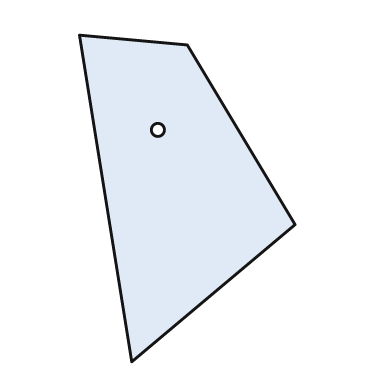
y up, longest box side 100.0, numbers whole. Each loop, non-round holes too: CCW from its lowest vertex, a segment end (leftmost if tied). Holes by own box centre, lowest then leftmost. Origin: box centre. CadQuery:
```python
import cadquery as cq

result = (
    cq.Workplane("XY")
    .moveTo(-17.0, -50.0)
    .lineTo(33.0, -8.0)
    .lineTo(0.0, 47.0)
    .lineTo(-33.0, 50.0)
    .close()
    .moveTo(-9.0, 21.0)
    .circle(2.0)
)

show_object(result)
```